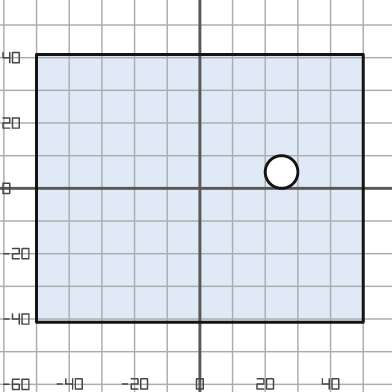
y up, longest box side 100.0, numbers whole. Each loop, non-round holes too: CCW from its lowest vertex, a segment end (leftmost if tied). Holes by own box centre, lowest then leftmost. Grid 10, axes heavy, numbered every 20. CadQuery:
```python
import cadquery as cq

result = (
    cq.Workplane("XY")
    .moveTo(-50.0, -41.0)
    .lineTo(50.0, -41.0)
    .lineTo(50.0, 41.0)
    .lineTo(-50.0, 41.0)
    .close()
    .moveTo(25.0, 5.0)
    .circle(5.0)
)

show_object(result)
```